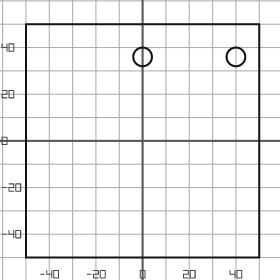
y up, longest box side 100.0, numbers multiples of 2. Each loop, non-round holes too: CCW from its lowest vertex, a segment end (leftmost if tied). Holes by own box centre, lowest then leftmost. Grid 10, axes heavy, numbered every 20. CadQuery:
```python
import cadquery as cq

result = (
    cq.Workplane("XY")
    .moveTo(-50.0, -50.0)
    .lineTo(50.0, -50.0)
    .lineTo(50.0, 50.0)
    .lineTo(-50.0, 50.0)
    .close()
    .moveTo(0.0, 36.0)
    .circle(4.0)
    .moveTo(40.0, 36.0)
    .circle(4.0)
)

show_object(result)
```